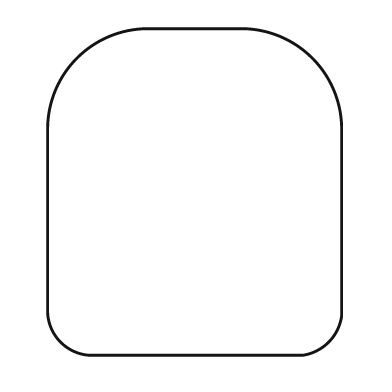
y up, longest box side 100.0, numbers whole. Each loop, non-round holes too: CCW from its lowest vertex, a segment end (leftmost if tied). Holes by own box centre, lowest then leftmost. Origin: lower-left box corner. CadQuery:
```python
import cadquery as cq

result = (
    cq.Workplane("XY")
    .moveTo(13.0, 0.0)
    .lineTo(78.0, 0.0)
    .threePointArc((86.0, 4.0), (90.0, 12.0))
    .lineTo(90.0, 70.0)
    .threePointArc((81.0, 91.0), (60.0, 100.0))
    .lineTo(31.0, 100.0)
    .threePointArc((9.0, 91.0), (0.0, 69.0))
    .lineTo(0.0, 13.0)
    .threePointArc((4.0, 4.0), (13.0, 0.0))
    .close()
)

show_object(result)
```